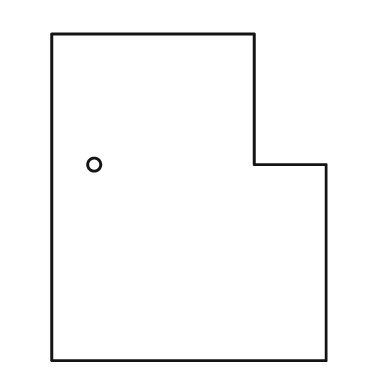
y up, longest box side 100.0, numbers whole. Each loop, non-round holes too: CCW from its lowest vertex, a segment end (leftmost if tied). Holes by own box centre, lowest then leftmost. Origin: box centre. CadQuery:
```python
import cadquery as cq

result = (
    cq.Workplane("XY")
    .moveTo(-42.0, -50.0)
    .lineTo(42.0, -50.0)
    .lineTo(42.0, 10.0)
    .lineTo(20.0, 10.0)
    .lineTo(20.0, 50.0)
    .lineTo(-42.0, 50.0)
    .close()
    .moveTo(-29.0, 10.0)
    .circle(2.0)
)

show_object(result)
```